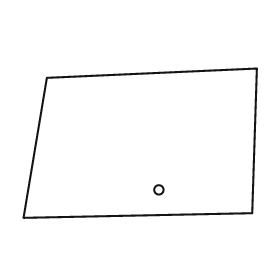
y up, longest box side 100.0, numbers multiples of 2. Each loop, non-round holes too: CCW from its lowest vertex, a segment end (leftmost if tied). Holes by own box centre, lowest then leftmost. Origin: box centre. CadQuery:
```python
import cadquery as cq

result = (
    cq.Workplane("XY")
    .moveTo(-50.0, -32.0)
    .lineTo(48.0, -30.0)
    .lineTo(50.0, 32.0)
    .lineTo(-40.0, 28.0)
    .close()
    .moveTo(8.0, -20.0)
    .circle(2.0)
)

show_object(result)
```